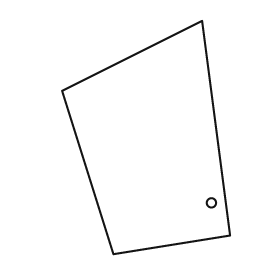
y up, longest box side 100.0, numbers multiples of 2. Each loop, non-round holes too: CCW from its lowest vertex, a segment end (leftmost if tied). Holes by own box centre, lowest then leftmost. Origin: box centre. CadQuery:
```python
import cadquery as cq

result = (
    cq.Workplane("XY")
    .moveTo(-14.0, -50.0)
    .lineTo(36.0, -42.0)
    .lineTo(24.0, 50.0)
    .lineTo(-36.0, 20.0)
    .close()
    .moveTo(28.0, -28.0)
    .circle(2.0)
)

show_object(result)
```